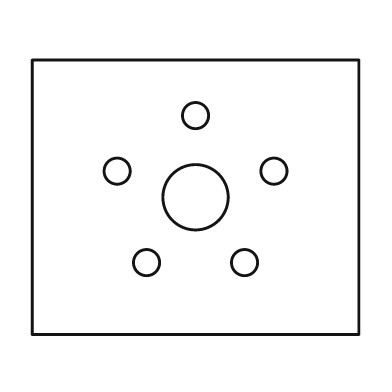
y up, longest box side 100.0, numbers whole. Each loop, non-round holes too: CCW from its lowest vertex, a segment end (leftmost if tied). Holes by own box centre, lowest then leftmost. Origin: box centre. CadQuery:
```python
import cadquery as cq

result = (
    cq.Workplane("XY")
    .moveTo(-50.0, -42.0)
    .lineTo(50.0, -42.0)
    .lineTo(50.0, 42.0)
    .lineTo(-50.0, 42.0)
    .close()
    .moveTo(-15.0, -20.0)
    .circle(4.0)
    .moveTo(15.0, -20.0)
    .circle(4.0)
    .moveTo(0.0, 0.0)
    .circle(10.0)
    .moveTo(-24.0, 8.0)
    .circle(4.0)
    .moveTo(24.0, 8.0)
    .circle(4.0)
    .moveTo(0.0, 25.0)
    .circle(4.0)
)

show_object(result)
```